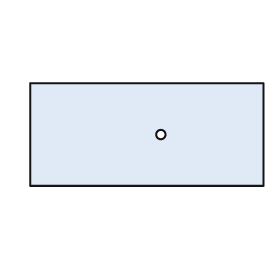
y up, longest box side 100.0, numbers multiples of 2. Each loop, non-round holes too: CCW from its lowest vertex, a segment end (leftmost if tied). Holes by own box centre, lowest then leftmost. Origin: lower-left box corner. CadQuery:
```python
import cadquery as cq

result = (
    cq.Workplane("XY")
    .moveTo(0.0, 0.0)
    .lineTo(100.0, 0.0)
    .lineTo(100.0, 44.0)
    .lineTo(0.0, 44.0)
    .close()
    .moveTo(56.0, 22.0)
    .circle(2.0)
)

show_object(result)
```